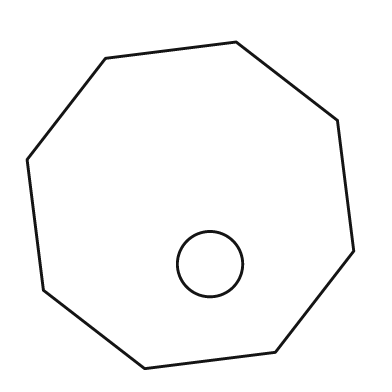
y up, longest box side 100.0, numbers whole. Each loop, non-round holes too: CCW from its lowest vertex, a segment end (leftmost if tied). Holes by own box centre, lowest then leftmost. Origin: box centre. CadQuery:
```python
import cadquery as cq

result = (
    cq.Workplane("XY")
    .moveTo(-14.0, -50.0)
    .lineTo(26.0, -45.0)
    .lineTo(50.0, -14.0)
    .lineTo(45.0, 26.0)
    .lineTo(14.0, 50.0)
    .lineTo(-26.0, 45.0)
    .lineTo(-50.0, 14.0)
    .lineTo(-45.0, -26.0)
    .close()
    .moveTo(6.0, -18.0)
    .circle(10.0)
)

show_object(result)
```